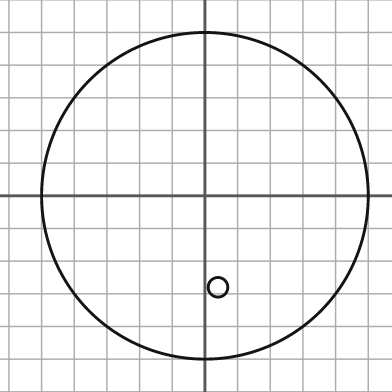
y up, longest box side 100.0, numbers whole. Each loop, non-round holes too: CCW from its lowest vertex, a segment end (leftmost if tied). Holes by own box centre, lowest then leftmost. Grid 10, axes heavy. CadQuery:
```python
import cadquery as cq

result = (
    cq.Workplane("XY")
    .moveTo(0.0, 0.0)
    .circle(50.0)
    .moveTo(4.0, -28.0)
    .circle(3.0)
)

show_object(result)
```